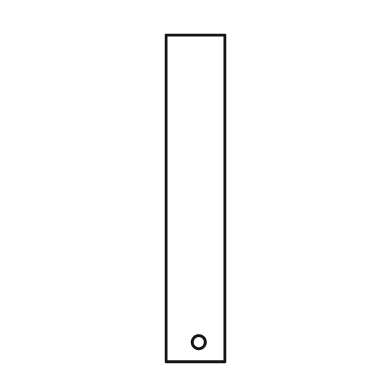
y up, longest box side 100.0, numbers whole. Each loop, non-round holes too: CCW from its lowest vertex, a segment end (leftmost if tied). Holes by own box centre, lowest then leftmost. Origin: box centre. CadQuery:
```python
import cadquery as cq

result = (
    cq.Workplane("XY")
    .moveTo(-9.0, -50.0)
    .lineTo(9.0, -50.0)
    .lineTo(9.0, 50.0)
    .lineTo(-9.0, 50.0)
    .close()
    .moveTo(1.0, -44.0)
    .circle(2.0)
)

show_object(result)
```